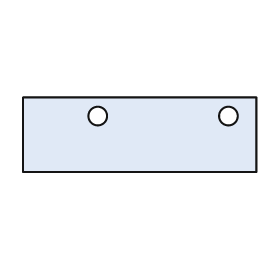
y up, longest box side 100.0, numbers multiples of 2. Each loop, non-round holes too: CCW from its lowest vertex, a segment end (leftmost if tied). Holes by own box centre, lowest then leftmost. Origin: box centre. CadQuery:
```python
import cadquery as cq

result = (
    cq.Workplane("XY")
    .moveTo(-50.0, -16.0)
    .lineTo(50.0, -16.0)
    .lineTo(50.0, 16.0)
    .lineTo(-50.0, 16.0)
    .close()
    .moveTo(-18.0, 8.0)
    .circle(4.0)
    .moveTo(38.0, 8.0)
    .circle(4.0)
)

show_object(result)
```